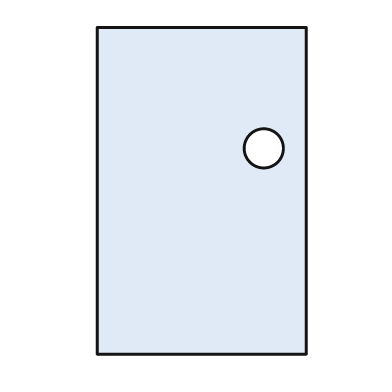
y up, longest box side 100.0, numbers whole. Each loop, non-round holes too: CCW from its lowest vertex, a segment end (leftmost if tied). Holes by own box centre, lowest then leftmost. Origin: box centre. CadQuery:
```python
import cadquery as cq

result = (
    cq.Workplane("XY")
    .moveTo(-32.0, -50.0)
    .lineTo(32.0, -50.0)
    .lineTo(32.0, 50.0)
    .lineTo(-32.0, 50.0)
    .close()
    .moveTo(19.0, 13.0)
    .circle(6.0)
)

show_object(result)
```